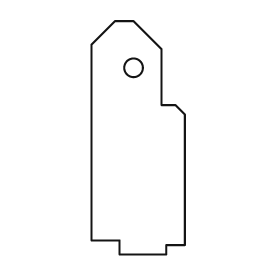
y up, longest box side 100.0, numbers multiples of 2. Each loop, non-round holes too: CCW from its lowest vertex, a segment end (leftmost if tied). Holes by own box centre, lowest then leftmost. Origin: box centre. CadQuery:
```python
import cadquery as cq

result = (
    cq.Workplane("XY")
    .moveTo(-8.0, -50.0)
    .lineTo(12.0, -50.0)
    .lineTo(12.0, -46.0)
    .lineTo(20.0, -46.0)
    .lineTo(20.0, 10.0)
    .lineTo(16.0, 14.0)
    .lineTo(10.0, 14.0)
    .lineTo(10.0, 38.0)
    .lineTo(-2.0, 50.0)
    .lineTo(-10.0, 50.0)
    .lineTo(-20.0, 40.0)
    .lineTo(-20.0, -44.0)
    .lineTo(-8.0, -44.0)
    .close()
    .moveTo(-2.0, 30.0)
    .circle(4.0)
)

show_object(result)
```